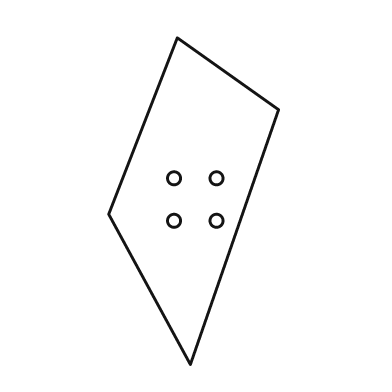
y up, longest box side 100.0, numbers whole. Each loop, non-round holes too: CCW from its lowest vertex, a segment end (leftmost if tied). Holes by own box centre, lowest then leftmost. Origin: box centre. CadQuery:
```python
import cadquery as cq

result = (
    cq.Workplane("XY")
    .moveTo(-1.0, -50.0)
    .lineTo(26.0, 28.0)
    .lineTo(-5.0, 50.0)
    .lineTo(-26.0, -4.0)
    .close()
    .moveTo(-6.0, -6.0)
    .circle(2.0)
    .moveTo(7.0, -6.0)
    .circle(2.0)
    .moveTo(-6.0, 7.0)
    .circle(2.0)
    .moveTo(7.0, 7.0)
    .circle(2.0)
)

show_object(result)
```